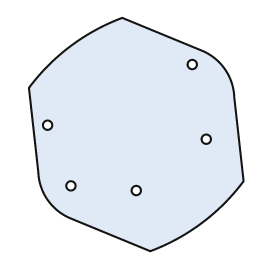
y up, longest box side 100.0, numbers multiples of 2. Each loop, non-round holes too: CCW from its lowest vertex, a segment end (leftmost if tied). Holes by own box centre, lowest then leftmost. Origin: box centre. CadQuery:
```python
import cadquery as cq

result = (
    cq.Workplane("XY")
    .moveTo(6.0, -50.0)
    .threePointArc((28.0, -38.0), (46.0, -20.0))
    .lineTo(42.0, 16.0)
    .threePointArc((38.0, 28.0), (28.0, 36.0))
    .lineTo(-6.0, 50.0)
    .threePointArc((-28.0, 38.0), (-46.0, 20.0))
    .lineTo(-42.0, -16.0)
    .threePointArc((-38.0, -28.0), (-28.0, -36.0))
    .close()
    .moveTo(0.0, -24.0)
    .circle(2.0)
    .moveTo(-28.0, -22.0)
    .circle(2.0)
    .moveTo(30.0, -2.0)
    .circle(2.0)
    .moveTo(-38.0, 4.0)
    .circle(2.0)
    .moveTo(24.0, 30.0)
    .circle(2.0)
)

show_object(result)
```